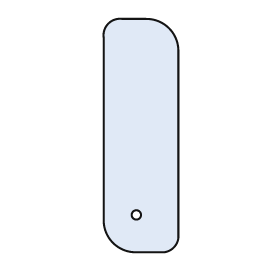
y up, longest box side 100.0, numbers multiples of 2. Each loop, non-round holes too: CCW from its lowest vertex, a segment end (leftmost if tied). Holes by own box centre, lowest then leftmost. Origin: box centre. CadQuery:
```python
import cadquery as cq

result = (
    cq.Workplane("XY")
    .moveTo(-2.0, -50.0)
    .lineTo(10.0, -50.0)
    .threePointArc((14.0, -48.0), (16.0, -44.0))
    .lineTo(16.0, 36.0)
    .threePointArc((12.0, 46.0), (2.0, 50.0))
    .lineTo(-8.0, 50.0)
    .threePointArc((-14.0, 48.0), (-16.0, 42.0))
    .lineTo(-16.0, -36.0)
    .threePointArc((-12.0, -46.0), (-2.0, -50.0))
    .close()
    .moveTo(-2.0, -34.0)
    .circle(2.0)
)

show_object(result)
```